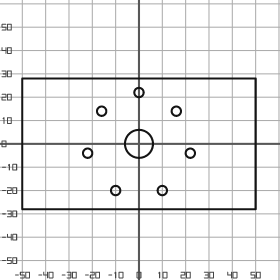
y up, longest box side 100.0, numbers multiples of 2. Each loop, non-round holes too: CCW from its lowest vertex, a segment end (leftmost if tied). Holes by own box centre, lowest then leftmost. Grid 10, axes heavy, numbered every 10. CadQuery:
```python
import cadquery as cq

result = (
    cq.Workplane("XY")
    .moveTo(-50.0, -28.0)
    .lineTo(50.0, -28.0)
    .lineTo(50.0, 28.0)
    .lineTo(-50.0, 28.0)
    .close()
    .moveTo(-10.0, -20.0)
    .circle(2.0)
    .moveTo(10.0, -20.0)
    .circle(2.0)
    .moveTo(-22.0, -4.0)
    .circle(2.0)
    .moveTo(22.0, -4.0)
    .circle(2.0)
    .moveTo(0.0, 0.0)
    .circle(6.0)
    .moveTo(-16.0, 14.0)
    .circle(2.0)
    .moveTo(16.0, 14.0)
    .circle(2.0)
    .moveTo(0.0, 22.0)
    .circle(2.0)
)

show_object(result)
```